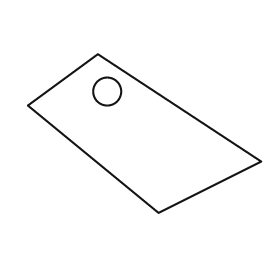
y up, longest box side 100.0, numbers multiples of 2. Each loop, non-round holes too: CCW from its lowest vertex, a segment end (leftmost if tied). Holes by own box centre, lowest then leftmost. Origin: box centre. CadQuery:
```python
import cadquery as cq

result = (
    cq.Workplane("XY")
    .moveTo(6.0, -34.0)
    .lineTo(50.0, -12.0)
    .lineTo(-20.0, 34.0)
    .lineTo(-50.0, 12.0)
    .close()
    .moveTo(-16.0, 18.0)
    .circle(6.0)
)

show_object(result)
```